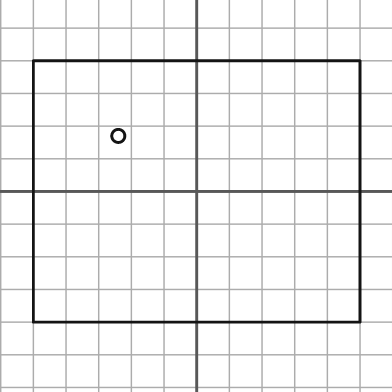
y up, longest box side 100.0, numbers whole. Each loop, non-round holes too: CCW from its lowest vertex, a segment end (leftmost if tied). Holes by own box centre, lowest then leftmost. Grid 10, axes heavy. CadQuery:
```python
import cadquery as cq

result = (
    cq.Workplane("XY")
    .moveTo(-50.0, -40.0)
    .lineTo(50.0, -40.0)
    .lineTo(50.0, 40.0)
    .lineTo(-50.0, 40.0)
    .close()
    .moveTo(-24.0, 17.0)
    .circle(2.0)
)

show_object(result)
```